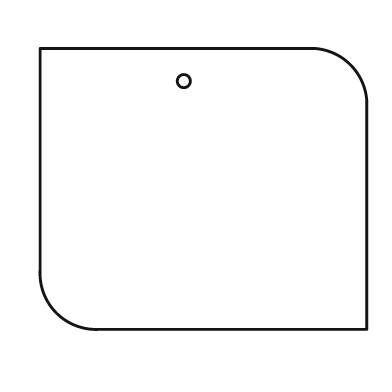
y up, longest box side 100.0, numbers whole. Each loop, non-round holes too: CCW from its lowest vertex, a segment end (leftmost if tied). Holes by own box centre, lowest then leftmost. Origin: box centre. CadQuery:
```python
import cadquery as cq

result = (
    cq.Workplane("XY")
    .moveTo(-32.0, -43.0)
    .lineTo(50.0, -43.0)
    .lineTo(50.0, 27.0)
    .threePointArc((45.0, 38.0), (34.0, 43.0))
    .lineTo(-50.0, 43.0)
    .lineTo(-50.0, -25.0)
    .threePointArc((-45.0, -38.0), (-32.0, -43.0))
    .close()
    .moveTo(-6.0, 33.0)
    .circle(2.0)
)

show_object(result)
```